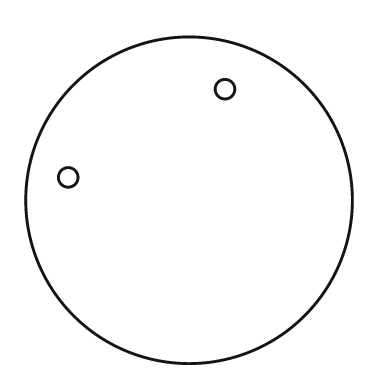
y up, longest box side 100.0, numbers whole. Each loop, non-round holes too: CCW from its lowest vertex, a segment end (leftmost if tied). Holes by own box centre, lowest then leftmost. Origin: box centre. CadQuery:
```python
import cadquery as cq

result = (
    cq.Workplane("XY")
    .moveTo(0.0, 0.0)
    .circle(50.0)
    .moveTo(-37.0, 7.0)
    .circle(3.0)
    .moveTo(11.0, 34.0)
    .circle(3.0)
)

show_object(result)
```